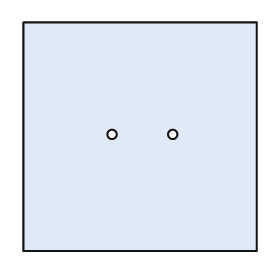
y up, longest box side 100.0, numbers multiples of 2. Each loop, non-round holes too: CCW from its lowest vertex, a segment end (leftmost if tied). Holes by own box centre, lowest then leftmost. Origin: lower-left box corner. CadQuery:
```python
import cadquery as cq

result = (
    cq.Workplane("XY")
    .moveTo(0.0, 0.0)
    .lineTo(100.0, 0.0)
    .lineTo(100.0, 98.0)
    .lineTo(0.0, 98.0)
    .close()
    .moveTo(38.0, 50.0)
    .circle(2.0)
    .moveTo(64.0, 50.0)
    .circle(2.0)
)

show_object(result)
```